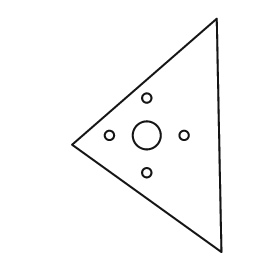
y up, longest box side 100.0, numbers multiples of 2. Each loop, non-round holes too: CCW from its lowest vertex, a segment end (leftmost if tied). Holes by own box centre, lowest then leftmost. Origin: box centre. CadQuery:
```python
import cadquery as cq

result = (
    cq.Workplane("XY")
    .moveTo(32.0, -50.0)
    .lineTo(30.0, 50.0)
    .lineTo(-32.0, -4.0)
    .close()
    .moveTo(0.0, -16.0)
    .circle(2.0)
    .moveTo(-16.0, 0.0)
    .circle(2.0)
    .moveTo(0.0, 0.0)
    .circle(6.0)
    .moveTo(16.0, 0.0)
    .circle(2.0)
    .moveTo(0.0, 16.0)
    .circle(2.0)
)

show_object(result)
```